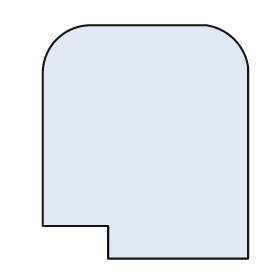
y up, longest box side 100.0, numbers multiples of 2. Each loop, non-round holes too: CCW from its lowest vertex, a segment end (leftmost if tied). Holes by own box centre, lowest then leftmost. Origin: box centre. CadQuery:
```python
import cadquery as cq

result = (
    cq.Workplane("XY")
    .moveTo(-16.0, -50.0)
    .lineTo(44.0, -50.0)
    .lineTo(44.0, 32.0)
    .threePointArc((38.0, 44.0), (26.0, 50.0))
    .lineTo(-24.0, 50.0)
    .threePointArc((-38.0, 44.0), (-44.0, 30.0))
    .lineTo(-44.0, -36.0)
    .lineTo(-16.0, -36.0)
    .close()
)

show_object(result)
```